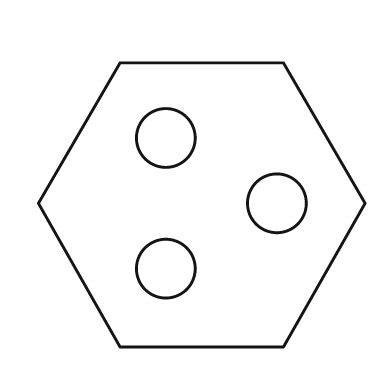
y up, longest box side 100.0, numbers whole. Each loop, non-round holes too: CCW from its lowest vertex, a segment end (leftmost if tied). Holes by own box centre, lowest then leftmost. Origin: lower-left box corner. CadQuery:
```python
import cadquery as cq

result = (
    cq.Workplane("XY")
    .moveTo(25.0, 0.0)
    .lineTo(75.0, 0.0)
    .lineTo(100.0, 44.0)
    .lineTo(75.0, 87.0)
    .lineTo(25.0, 87.0)
    .lineTo(0.0, 44.0)
    .close()
    .moveTo(39.0, 24.0)
    .circle(9.0)
    .moveTo(73.0, 44.0)
    .circle(9.0)
    .moveTo(39.0, 64.0)
    .circle(9.0)
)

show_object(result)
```